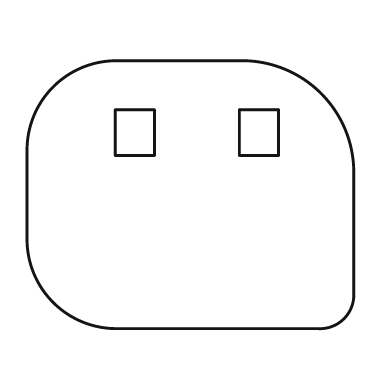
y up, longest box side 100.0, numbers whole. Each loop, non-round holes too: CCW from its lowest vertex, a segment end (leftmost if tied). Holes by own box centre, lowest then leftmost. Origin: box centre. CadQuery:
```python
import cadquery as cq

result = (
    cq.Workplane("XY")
    .moveTo(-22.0, -41.0)
    .lineTo(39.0, -41.0)
    .threePointArc((47.0, -38.0), (50.0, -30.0))
    .lineTo(50.0, 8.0)
    .threePointArc((40.0, 31.0), (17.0, 41.0))
    .lineTo(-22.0, 41.0)
    .threePointArc((-42.0, 33.0), (-50.0, 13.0))
    .lineTo(-50.0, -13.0)
    .threePointArc((-42.0, -33.0), (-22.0, -41.0))
    .close()
    .moveTo(-23.0, 12.0)
    .lineTo(-11.0, 12.0)
    .lineTo(-11.0, 26.0)
    .lineTo(-23.0, 26.0)
    .close()
    .moveTo(15.0, 12.0)
    .lineTo(27.0, 12.0)
    .lineTo(27.0, 26.0)
    .lineTo(15.0, 26.0)
    .close()
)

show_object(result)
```